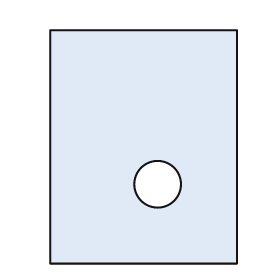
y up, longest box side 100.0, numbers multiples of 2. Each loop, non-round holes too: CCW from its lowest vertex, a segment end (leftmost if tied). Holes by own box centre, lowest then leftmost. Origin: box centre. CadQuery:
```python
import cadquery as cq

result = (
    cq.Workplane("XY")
    .moveTo(-40.0, -50.0)
    .lineTo(40.0, -50.0)
    .lineTo(40.0, 50.0)
    .lineTo(-40.0, 50.0)
    .close()
    .moveTo(6.0, -16.0)
    .circle(10.0)
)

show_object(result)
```